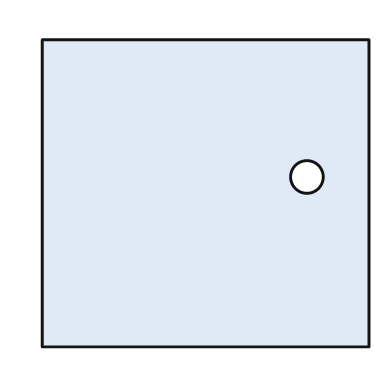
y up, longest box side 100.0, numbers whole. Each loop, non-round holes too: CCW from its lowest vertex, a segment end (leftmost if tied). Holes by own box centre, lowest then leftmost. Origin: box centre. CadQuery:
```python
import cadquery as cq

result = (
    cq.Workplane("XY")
    .moveTo(-50.0, -47.0)
    .lineTo(50.0, -47.0)
    .lineTo(50.0, 47.0)
    .lineTo(-50.0, 47.0)
    .close()
    .moveTo(31.0, 5.0)
    .circle(5.0)
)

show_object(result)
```